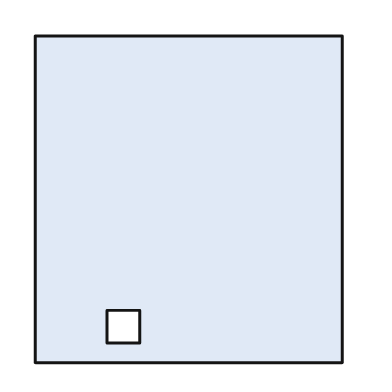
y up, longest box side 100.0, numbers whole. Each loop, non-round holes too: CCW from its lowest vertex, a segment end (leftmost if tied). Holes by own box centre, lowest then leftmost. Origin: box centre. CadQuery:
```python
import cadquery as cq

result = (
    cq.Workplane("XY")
    .moveTo(-47.0, -50.0)
    .lineTo(47.0, -50.0)
    .lineTo(47.0, 50.0)
    .lineTo(-47.0, 50.0)
    .close()
    .moveTo(-25.0, -44.0)
    .lineTo(-15.0, -44.0)
    .lineTo(-15.0, -34.0)
    .lineTo(-25.0, -34.0)
    .close()
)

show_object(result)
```